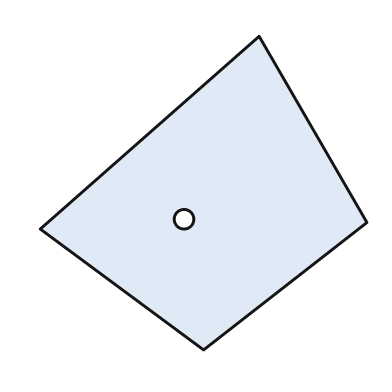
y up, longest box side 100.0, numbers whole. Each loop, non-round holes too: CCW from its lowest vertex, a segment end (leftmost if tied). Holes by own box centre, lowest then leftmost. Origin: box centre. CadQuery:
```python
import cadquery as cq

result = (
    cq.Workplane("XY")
    .moveTo(0.0, -48.0)
    .lineTo(50.0, -9.0)
    .lineTo(17.0, 48.0)
    .lineTo(-50.0, -11.0)
    .close()
    .moveTo(-6.0, -8.0)
    .circle(3.0)
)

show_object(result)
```